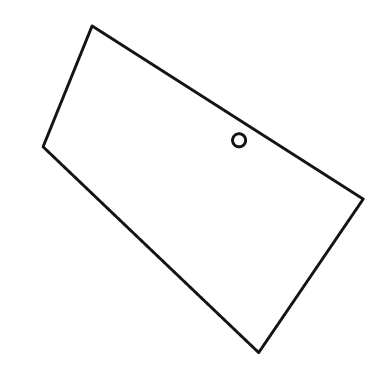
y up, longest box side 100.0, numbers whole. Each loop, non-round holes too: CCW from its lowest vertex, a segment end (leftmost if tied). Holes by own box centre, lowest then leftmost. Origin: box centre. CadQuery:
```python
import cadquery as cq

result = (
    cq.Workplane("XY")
    .moveTo(17.0, -50.0)
    .lineTo(49.0, -3.0)
    .lineTo(-34.0, 50.0)
    .lineTo(-49.0, 13.0)
    .close()
    .moveTo(11.0, 15.0)
    .circle(2.0)
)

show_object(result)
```